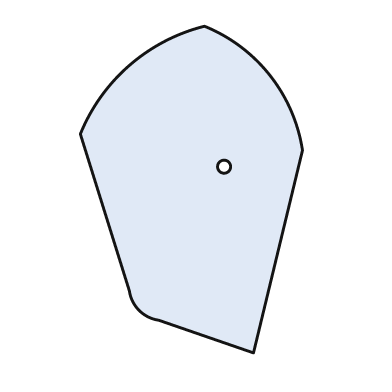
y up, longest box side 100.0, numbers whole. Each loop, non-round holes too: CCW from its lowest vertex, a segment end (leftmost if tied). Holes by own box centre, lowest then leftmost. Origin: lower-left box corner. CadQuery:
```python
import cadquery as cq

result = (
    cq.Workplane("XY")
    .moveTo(53.0, 0.0)
    .lineTo(68.0, 62.0)
    .threePointArc((58.0, 85.0), (38.0, 100.0))
    .threePointArc((15.0, 88.0), (0.0, 67.0))
    .lineTo(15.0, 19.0)
    .threePointArc((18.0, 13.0), (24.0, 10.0))
    .close()
    .moveTo(44.0, 57.0)
    .circle(2.0)
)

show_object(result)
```